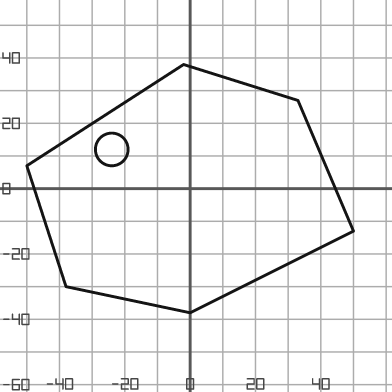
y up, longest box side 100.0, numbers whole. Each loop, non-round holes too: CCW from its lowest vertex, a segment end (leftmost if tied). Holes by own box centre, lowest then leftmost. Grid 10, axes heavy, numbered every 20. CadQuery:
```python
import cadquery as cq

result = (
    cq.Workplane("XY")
    .moveTo(0.0, -38.0)
    .lineTo(50.0, -13.0)
    .lineTo(33.0, 27.0)
    .lineTo(-2.0, 38.0)
    .lineTo(-50.0, 7.0)
    .lineTo(-38.0, -30.0)
    .close()
    .moveTo(-24.0, 12.0)
    .circle(5.0)
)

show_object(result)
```